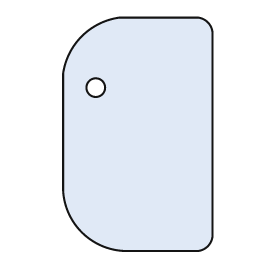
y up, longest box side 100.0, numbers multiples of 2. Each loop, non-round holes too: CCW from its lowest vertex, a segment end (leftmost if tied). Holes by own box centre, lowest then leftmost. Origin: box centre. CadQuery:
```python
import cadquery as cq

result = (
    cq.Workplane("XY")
    .moveTo(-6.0, -50.0)
    .lineTo(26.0, -50.0)
    .threePointArc((30.0, -48.0), (32.0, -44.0))
    .lineTo(32.0, 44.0)
    .threePointArc((30.0, 48.0), (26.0, 50.0))
    .lineTo(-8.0, 50.0)
    .threePointArc((-24.0, 42.0), (-32.0, 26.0))
    .lineTo(-32.0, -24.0)
    .threePointArc((-24.0, -42.0), (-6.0, -50.0))
    .close()
    .moveTo(-18.0, 20.0)
    .circle(4.0)
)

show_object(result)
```